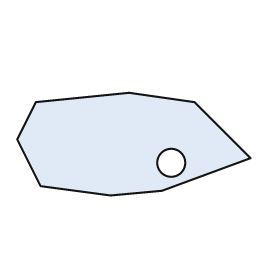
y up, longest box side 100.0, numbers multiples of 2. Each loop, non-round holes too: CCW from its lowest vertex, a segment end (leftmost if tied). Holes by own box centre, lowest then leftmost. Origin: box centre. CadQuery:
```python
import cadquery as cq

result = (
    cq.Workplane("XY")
    .moveTo(-10.0, -22.0)
    .lineTo(12.0, -20.0)
    .lineTo(50.0, -6.0)
    .lineTo(26.0, 18.0)
    .lineTo(-2.0, 22.0)
    .lineTo(-42.0, 18.0)
    .lineTo(-50.0, 2.0)
    .lineTo(-40.0, -18.0)
    .close()
    .moveTo(16.0, -8.0)
    .circle(6.0)
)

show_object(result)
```